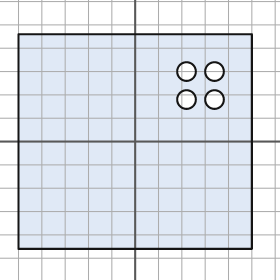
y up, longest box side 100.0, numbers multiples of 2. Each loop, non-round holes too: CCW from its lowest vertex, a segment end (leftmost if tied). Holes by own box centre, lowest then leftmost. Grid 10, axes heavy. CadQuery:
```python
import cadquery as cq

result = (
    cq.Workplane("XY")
    .moveTo(-50.0, -46.0)
    .lineTo(50.0, -46.0)
    .lineTo(50.0, 46.0)
    .lineTo(-50.0, 46.0)
    .close()
    .moveTo(22.0, 18.0)
    .circle(4.0)
    .moveTo(34.0, 18.0)
    .circle(4.0)
    .moveTo(22.0, 30.0)
    .circle(4.0)
    .moveTo(34.0, 30.0)
    .circle(4.0)
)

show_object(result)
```